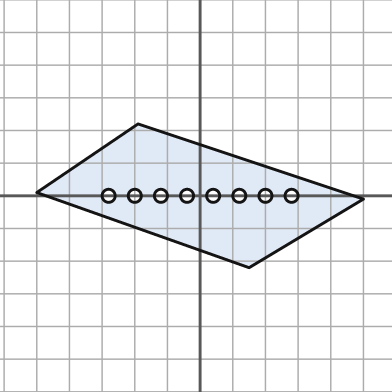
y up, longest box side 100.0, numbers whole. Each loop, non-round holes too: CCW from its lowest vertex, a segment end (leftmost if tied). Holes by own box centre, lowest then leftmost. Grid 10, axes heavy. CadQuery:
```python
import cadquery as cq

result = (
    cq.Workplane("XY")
    .moveTo(15.0, -22.0)
    .lineTo(50.0, -1.0)
    .lineTo(-19.0, 22.0)
    .lineTo(-50.0, 1.0)
    .close()
    .moveTo(-28.0, 0.0)
    .circle(2.0)
    .moveTo(-20.0, 0.0)
    .circle(2.0)
    .moveTo(-12.0, 0.0)
    .circle(2.0)
    .moveTo(-4.0, 0.0)
    .circle(2.0)
    .moveTo(4.0, 0.0)
    .circle(2.0)
    .moveTo(12.0, 0.0)
    .circle(2.0)
    .moveTo(20.0, 0.0)
    .circle(2.0)
    .moveTo(28.0, 0.0)
    .circle(2.0)
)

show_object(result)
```